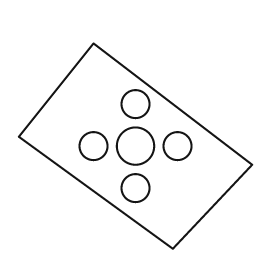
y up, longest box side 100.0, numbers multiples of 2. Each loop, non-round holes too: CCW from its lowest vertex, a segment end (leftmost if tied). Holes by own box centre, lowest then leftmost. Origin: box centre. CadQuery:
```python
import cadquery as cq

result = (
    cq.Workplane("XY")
    .moveTo(16.0, -44.0)
    .lineTo(50.0, -8.0)
    .lineTo(-18.0, 44.0)
    .lineTo(-50.0, 4.0)
    .close()
    .moveTo(0.0, -18.0)
    .circle(6.0)
    .moveTo(-18.0, 0.0)
    .circle(6.0)
    .moveTo(0.0, 0.0)
    .circle(8.0)
    .moveTo(18.0, 0.0)
    .circle(6.0)
    .moveTo(0.0, 18.0)
    .circle(6.0)
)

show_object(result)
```